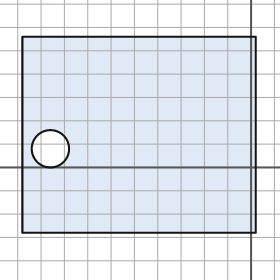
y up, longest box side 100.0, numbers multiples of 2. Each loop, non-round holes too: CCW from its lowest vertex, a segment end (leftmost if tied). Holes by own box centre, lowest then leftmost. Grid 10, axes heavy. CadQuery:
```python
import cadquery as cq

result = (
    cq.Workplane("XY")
    .moveTo(-98.0, -28.0)
    .lineTo(2.0, -28.0)
    .lineTo(2.0, 56.0)
    .lineTo(-98.0, 56.0)
    .close()
    .moveTo(-86.0, 8.0)
    .circle(8.0)
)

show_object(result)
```